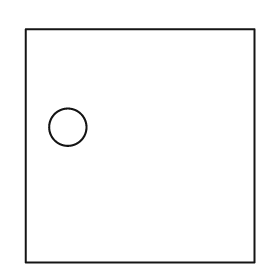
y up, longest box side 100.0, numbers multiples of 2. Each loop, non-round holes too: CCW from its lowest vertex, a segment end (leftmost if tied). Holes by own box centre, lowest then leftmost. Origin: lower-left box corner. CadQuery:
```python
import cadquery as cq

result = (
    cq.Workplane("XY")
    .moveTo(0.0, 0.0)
    .lineTo(98.0, 0.0)
    .lineTo(98.0, 100.0)
    .lineTo(0.0, 100.0)
    .close()
    .moveTo(18.0, 58.0)
    .circle(8.0)
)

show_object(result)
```